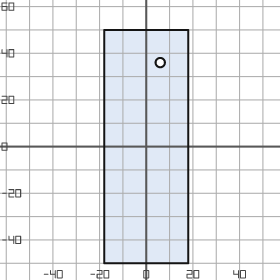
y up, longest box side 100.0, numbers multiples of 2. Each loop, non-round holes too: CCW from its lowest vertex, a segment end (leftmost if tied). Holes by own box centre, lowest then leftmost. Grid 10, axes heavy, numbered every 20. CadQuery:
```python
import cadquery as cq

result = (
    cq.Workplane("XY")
    .moveTo(-18.0, -50.0)
    .lineTo(18.0, -50.0)
    .lineTo(18.0, 50.0)
    .lineTo(-18.0, 50.0)
    .close()
    .moveTo(6.0, 36.0)
    .circle(2.0)
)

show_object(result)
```